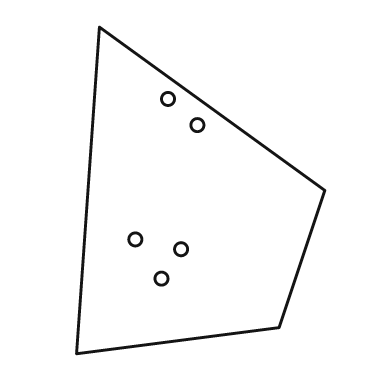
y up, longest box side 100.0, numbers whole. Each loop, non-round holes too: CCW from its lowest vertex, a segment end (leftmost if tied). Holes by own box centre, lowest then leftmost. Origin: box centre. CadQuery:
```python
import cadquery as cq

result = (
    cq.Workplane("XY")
    .moveTo(-38.0, -50.0)
    .lineTo(24.0, -42.0)
    .lineTo(38.0, 0.0)
    .lineTo(-31.0, 50.0)
    .close()
    .moveTo(-12.0, -27.0)
    .circle(2.0)
    .moveTo(-6.0, -18.0)
    .circle(2.0)
    .moveTo(-20.0, -15.0)
    .circle(2.0)
    .moveTo(-1.0, 20.0)
    .circle(2.0)
    .moveTo(-10.0, 28.0)
    .circle(2.0)
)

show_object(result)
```